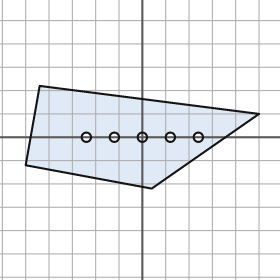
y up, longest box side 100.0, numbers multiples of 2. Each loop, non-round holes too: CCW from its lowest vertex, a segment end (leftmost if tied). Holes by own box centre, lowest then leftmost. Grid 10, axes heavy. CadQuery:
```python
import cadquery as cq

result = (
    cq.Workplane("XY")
    .moveTo(4.0, -22.0)
    .lineTo(50.0, 10.0)
    .lineTo(-44.0, 22.0)
    .lineTo(-50.0, -12.0)
    .close()
    .moveTo(-24.0, 0.0)
    .circle(2.0)
    .moveTo(-12.0, 0.0)
    .circle(2.0)
    .moveTo(0.0, 0.0)
    .circle(2.0)
    .moveTo(12.0, 0.0)
    .circle(2.0)
    .moveTo(24.0, 0.0)
    .circle(2.0)
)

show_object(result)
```